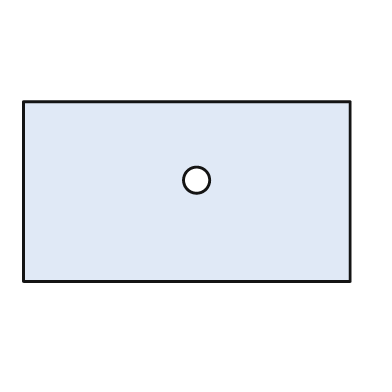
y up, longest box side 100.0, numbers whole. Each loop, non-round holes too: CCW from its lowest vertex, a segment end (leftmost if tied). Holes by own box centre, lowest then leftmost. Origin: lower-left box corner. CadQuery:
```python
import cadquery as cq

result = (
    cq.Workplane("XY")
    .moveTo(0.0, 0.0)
    .lineTo(100.0, 0.0)
    .lineTo(100.0, 55.0)
    .lineTo(0.0, 55.0)
    .close()
    .moveTo(53.0, 31.0)
    .circle(4.0)
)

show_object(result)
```